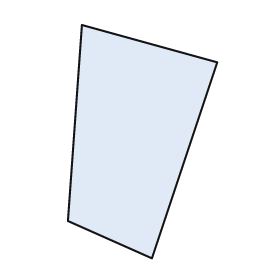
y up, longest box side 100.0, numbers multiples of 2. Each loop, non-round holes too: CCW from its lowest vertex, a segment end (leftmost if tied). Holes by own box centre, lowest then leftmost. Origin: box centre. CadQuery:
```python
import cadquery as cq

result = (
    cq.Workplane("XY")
    .moveTo(4.0, -50.0)
    .lineTo(32.0, 34.0)
    .lineTo(-26.0, 50.0)
    .lineTo(-32.0, -34.0)
    .close()
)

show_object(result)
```